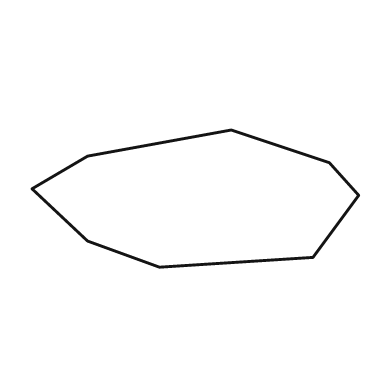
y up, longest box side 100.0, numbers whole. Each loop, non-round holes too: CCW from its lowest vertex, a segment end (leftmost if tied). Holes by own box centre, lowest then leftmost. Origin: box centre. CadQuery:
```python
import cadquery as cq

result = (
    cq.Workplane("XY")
    .moveTo(-11.0, -21.0)
    .lineTo(36.0, -18.0)
    .lineTo(50.0, 1.0)
    .lineTo(41.0, 11.0)
    .lineTo(11.0, 21.0)
    .lineTo(-33.0, 13.0)
    .lineTo(-50.0, 3.0)
    .lineTo(-33.0, -13.0)
    .close()
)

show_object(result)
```